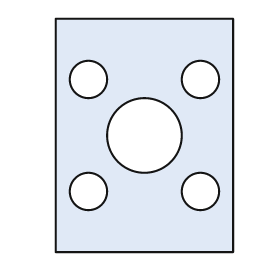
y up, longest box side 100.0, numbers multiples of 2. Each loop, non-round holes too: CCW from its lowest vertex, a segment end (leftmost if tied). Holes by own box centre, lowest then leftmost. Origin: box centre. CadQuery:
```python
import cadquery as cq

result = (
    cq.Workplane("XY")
    .moveTo(-38.0, -50.0)
    .lineTo(38.0, -50.0)
    .lineTo(38.0, 50.0)
    .lineTo(-38.0, 50.0)
    .close()
    .moveTo(-24.0, -24.0)
    .circle(8.0)
    .moveTo(24.0, -24.0)
    .circle(8.0)
    .moveTo(0.0, 0.0)
    .circle(16.0)
    .moveTo(-24.0, 24.0)
    .circle(8.0)
    .moveTo(24.0, 24.0)
    .circle(8.0)
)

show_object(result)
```